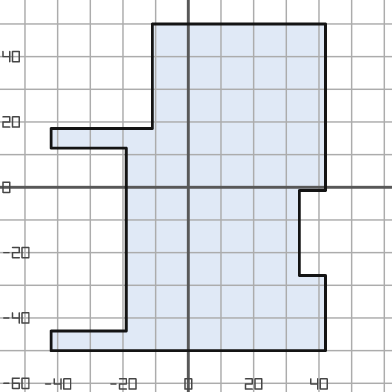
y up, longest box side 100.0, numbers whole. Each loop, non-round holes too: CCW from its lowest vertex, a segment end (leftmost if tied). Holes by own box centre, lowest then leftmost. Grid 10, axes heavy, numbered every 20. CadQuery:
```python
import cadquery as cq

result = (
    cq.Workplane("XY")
    .moveTo(-42.0, -50.0)
    .lineTo(42.0, -50.0)
    .lineTo(42.0, -27.0)
    .lineTo(34.0, -27.0)
    .lineTo(34.0, -1.0)
    .lineTo(42.0, -1.0)
    .lineTo(42.0, 50.0)
    .lineTo(-11.0, 50.0)
    .lineTo(-11.0, 18.0)
    .lineTo(-42.0, 18.0)
    .lineTo(-42.0, 12.0)
    .lineTo(-19.0, 12.0)
    .lineTo(-19.0, -44.0)
    .lineTo(-42.0, -44.0)
    .close()
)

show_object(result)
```